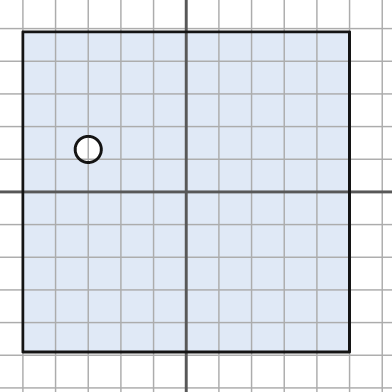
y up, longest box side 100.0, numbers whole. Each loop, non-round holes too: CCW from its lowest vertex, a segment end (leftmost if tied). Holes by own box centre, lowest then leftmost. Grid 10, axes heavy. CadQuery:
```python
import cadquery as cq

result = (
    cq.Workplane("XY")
    .moveTo(-50.0, -49.0)
    .lineTo(50.0, -49.0)
    .lineTo(50.0, 49.0)
    .lineTo(-50.0, 49.0)
    .close()
    .moveTo(-30.0, 13.0)
    .circle(4.0)
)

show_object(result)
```